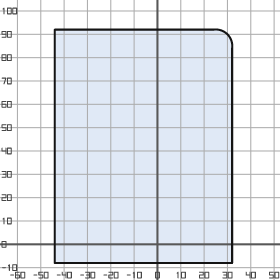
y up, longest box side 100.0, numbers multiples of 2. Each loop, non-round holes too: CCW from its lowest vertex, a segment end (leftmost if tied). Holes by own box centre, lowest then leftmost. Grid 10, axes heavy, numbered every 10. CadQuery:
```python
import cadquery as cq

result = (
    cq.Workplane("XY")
    .moveTo(-44.0, -8.0)
    .lineTo(32.0, -8.0)
    .lineTo(32.0, 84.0)
    .threePointArc((30.0, 90.0), (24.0, 92.0))
    .lineTo(-44.0, 92.0)
    .close()
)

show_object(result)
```